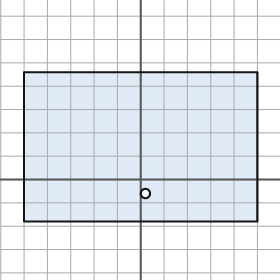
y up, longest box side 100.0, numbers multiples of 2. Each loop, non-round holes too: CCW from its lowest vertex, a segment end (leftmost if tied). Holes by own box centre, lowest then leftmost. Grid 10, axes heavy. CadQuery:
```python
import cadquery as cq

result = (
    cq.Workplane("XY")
    .moveTo(-50.0, -18.0)
    .lineTo(50.0, -18.0)
    .lineTo(50.0, 46.0)
    .lineTo(-50.0, 46.0)
    .close()
    .moveTo(2.0, -6.0)
    .circle(2.0)
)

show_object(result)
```